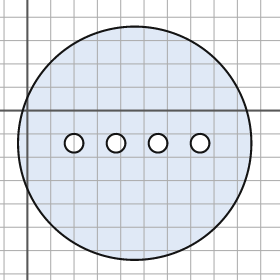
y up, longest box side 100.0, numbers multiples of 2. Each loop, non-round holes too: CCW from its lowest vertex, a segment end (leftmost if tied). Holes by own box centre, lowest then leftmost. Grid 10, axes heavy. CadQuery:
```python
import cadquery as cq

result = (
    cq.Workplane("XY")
    .moveTo(46.0, -14.0)
    .circle(50.0)
    .moveTo(20.0, -14.0)
    .circle(4.0)
    .moveTo(38.0, -14.0)
    .circle(4.0)
    .moveTo(56.0, -14.0)
    .circle(4.0)
    .moveTo(74.0, -14.0)
    .circle(4.0)
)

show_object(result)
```